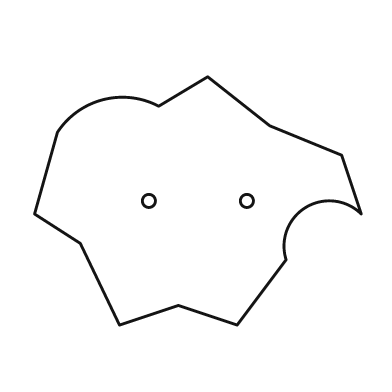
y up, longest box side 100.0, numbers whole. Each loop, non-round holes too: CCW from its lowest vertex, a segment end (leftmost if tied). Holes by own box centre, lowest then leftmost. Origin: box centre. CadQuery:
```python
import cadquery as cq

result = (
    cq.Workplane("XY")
    .moveTo(-24.0, -38.0)
    .lineTo(-6.0, -32.0)
    .lineTo(12.0, -38.0)
    .lineTo(27.0, -18.0)
    .threePointArc((33.0, -2.0), (50.0, -4.0))
    .lineTo(44.0, 14.0)
    .lineTo(22.0, 23.0)
    .lineTo(3.0, 38.0)
    .lineTo(-12.0, 29.0)
    .threePointArc((-29.0, 31.0), (-43.0, 21.0))
    .lineTo(-50.0, -4.0)
    .lineTo(-36.0, -13.0)
    .close()
    .moveTo(-15.0, 0.0)
    .circle(2.0)
    .moveTo(15.0, 0.0)
    .circle(2.0)
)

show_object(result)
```